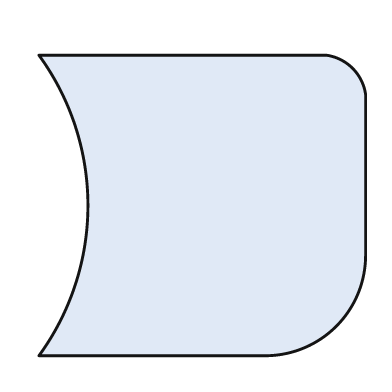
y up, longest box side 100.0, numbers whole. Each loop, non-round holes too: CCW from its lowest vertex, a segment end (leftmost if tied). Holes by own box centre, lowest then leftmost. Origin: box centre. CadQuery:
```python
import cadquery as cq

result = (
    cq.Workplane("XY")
    .moveTo(-50.0, -46.0)
    .lineTo(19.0, -46.0)
    .threePointArc((41.0, -37.0), (50.0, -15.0))
    .lineTo(50.0, 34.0)
    .threePointArc((46.0, 42.0), (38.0, 46.0))
    .lineTo(-50.0, 46.0)
    .threePointArc((-35.0, 0.0), (-50.0, -46.0))
    .close()
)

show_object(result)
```